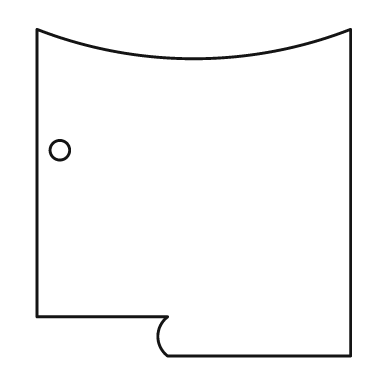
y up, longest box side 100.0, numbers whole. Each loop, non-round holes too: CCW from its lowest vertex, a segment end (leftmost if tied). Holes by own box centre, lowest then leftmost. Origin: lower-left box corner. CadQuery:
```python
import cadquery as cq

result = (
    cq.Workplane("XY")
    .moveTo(40.0, 0.0)
    .lineTo(96.0, 0.0)
    .lineTo(96.0, 100.0)
    .threePointArc((48.0, 91.0), (0.0, 100.0))
    .lineTo(0.0, 12.0)
    .lineTo(40.0, 12.0)
    .threePointArc((37.0, 6.0), (40.0, 0.0))
    .close()
    .moveTo(7.0, 63.0)
    .circle(3.0)
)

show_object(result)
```